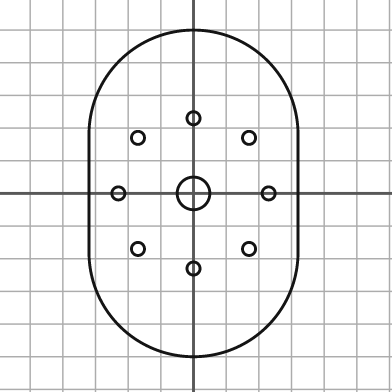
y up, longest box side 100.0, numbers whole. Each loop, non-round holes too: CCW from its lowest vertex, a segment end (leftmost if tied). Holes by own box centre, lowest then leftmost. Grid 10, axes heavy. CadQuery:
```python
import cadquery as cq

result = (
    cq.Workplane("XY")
    .moveTo(-32.0, -18.0)
    .threePointArc((0.0, -50.0), (32.0, -18.0))
    .lineTo(32.0, 18.0)
    .threePointArc((0.0, 50.0), (-32.0, 18.0))
    .close()
    .moveTo(0.0, -23.0)
    .circle(2.0)
    .moveTo(-17.0, -17.0)
    .circle(2.0)
    .moveTo(17.0, -17.0)
    .circle(2.0)
    .moveTo(-23.0, 0.0)
    .circle(2.0)
    .moveTo(0.0, 0.0)
    .circle(5.0)
    .moveTo(23.0, 0.0)
    .circle(2.0)
    .moveTo(-17.0, 17.0)
    .circle(2.0)
    .moveTo(17.0, 17.0)
    .circle(2.0)
    .moveTo(0.0, 23.0)
    .circle(2.0)
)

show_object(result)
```